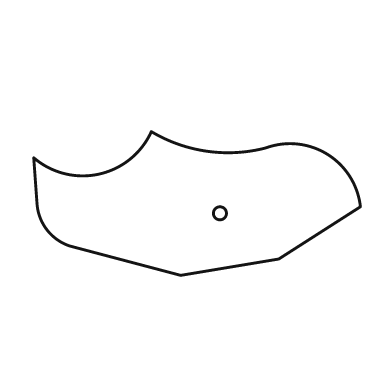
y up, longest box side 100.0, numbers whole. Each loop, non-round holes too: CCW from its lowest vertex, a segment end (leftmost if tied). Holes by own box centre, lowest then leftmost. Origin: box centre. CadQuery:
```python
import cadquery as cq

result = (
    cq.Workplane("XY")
    .moveTo(-5.0, -22.0)
    .lineTo(25.0, -17.0)
    .lineTo(50.0, -1.0)
    .threePointArc((40.0, 15.0), (21.0, 17.0))
    .threePointArc((3.0, 16.0), (-14.0, 22.0))
    .threePointArc((-30.0, 9.0), (-50.0, 14.0))
    .lineTo(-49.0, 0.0)
    .threePointArc((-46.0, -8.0), (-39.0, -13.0))
    .close()
    .moveTo(7.0, -3.0)
    .circle(2.0)
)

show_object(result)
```